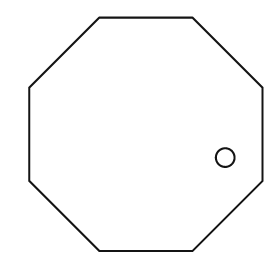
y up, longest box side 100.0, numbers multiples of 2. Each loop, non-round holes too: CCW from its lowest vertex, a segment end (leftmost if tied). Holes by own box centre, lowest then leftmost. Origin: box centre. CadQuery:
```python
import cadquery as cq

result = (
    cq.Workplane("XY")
    .moveTo(-20.0, -50.0)
    .lineTo(20.0, -50.0)
    .lineTo(50.0, -20.0)
    .lineTo(50.0, 20.0)
    .lineTo(20.0, 50.0)
    .lineTo(-20.0, 50.0)
    .lineTo(-50.0, 20.0)
    .lineTo(-50.0, -20.0)
    .close()
    .moveTo(34.0, -10.0)
    .circle(4.0)
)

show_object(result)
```